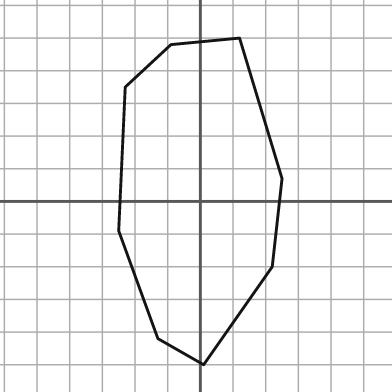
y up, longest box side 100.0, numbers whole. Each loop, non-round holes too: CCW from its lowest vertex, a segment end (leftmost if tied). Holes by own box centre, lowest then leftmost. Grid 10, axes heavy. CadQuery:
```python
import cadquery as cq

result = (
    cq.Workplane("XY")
    .moveTo(1.0, -50.0)
    .lineTo(22.0, -20.0)
    .lineTo(25.0, 7.0)
    .lineTo(12.0, 50.0)
    .lineTo(-9.0, 48.0)
    .lineTo(-23.0, 35.0)
    .lineTo(-25.0, -9.0)
    .lineTo(-13.0, -42.0)
    .close()
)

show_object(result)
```